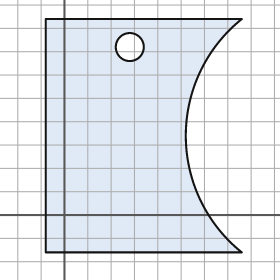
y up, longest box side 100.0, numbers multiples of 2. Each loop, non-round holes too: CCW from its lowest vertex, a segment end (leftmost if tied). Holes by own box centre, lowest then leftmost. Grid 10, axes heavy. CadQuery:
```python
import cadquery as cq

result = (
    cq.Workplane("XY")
    .moveTo(-8.0, -16.0)
    .lineTo(76.0, -16.0)
    .threePointArc((52.0, 34.0), (76.0, 84.0))
    .lineTo(-8.0, 84.0)
    .close()
    .moveTo(28.0, 72.0)
    .circle(6.0)
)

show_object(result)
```